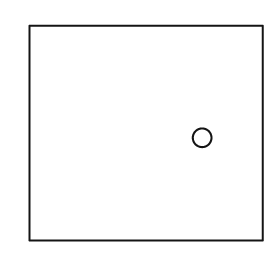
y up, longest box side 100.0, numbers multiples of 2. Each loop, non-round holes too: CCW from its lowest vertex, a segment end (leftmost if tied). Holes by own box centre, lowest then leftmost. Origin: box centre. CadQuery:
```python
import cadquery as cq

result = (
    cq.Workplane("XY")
    .moveTo(-50.0, -46.0)
    .lineTo(50.0, -46.0)
    .lineTo(50.0, 46.0)
    .lineTo(-50.0, 46.0)
    .close()
    .moveTo(24.0, -2.0)
    .circle(4.0)
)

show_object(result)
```